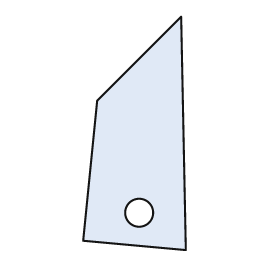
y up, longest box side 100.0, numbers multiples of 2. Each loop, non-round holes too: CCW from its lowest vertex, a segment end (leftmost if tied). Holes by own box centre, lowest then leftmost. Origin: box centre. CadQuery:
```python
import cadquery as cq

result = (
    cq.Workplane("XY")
    .moveTo(22.0, -50.0)
    .lineTo(20.0, 50.0)
    .lineTo(-16.0, 14.0)
    .lineTo(-22.0, -46.0)
    .close()
    .moveTo(2.0, -34.0)
    .circle(6.0)
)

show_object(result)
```